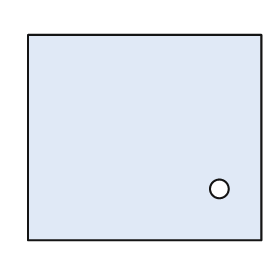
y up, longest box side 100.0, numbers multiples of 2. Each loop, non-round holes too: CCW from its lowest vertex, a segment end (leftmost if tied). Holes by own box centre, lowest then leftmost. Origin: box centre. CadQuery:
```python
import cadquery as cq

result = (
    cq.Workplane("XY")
    .moveTo(-50.0, -44.0)
    .lineTo(50.0, -44.0)
    .lineTo(50.0, 44.0)
    .lineTo(-50.0, 44.0)
    .close()
    .moveTo(32.0, -22.0)
    .circle(4.0)
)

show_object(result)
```